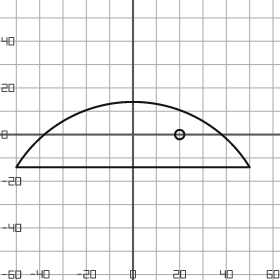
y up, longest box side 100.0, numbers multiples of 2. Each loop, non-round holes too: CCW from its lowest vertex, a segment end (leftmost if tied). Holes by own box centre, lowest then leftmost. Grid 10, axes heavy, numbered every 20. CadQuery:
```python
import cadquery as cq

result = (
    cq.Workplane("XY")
    .moveTo(-50.0, -14.0)
    .lineTo(50.0, -14.0)
    .threePointArc((0.0, 14.0), (-50.0, -14.0))
    .close()
    .moveTo(20.0, 0.0)
    .circle(2.0)
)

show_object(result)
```